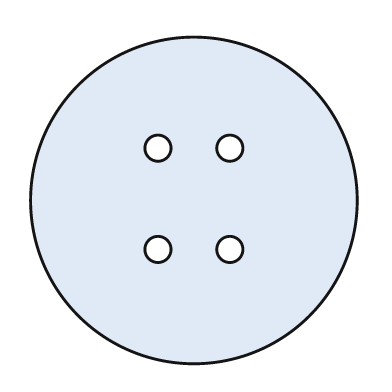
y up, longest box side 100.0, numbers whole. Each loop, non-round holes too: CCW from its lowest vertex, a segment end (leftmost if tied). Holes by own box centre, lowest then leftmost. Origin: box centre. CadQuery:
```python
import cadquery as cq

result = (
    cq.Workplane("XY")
    .moveTo(0.0, 0.0)
    .circle(50.0)
    .moveTo(-11.0, -15.0)
    .circle(4.0)
    .moveTo(11.0, -15.0)
    .circle(4.0)
    .moveTo(-11.0, 16.0)
    .circle(4.0)
    .moveTo(11.0, 16.0)
    .circle(4.0)
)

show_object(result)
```